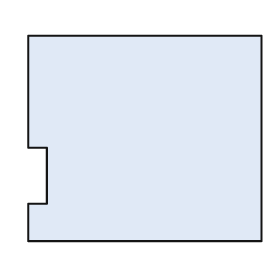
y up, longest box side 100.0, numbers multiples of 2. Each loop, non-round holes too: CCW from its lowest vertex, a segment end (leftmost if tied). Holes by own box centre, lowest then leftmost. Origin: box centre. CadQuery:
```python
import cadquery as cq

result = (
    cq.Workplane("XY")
    .moveTo(-50.0, -44.0)
    .lineTo(50.0, -44.0)
    .lineTo(50.0, 44.0)
    .lineTo(-50.0, 44.0)
    .lineTo(-50.0, -4.0)
    .lineTo(-42.0, -4.0)
    .lineTo(-42.0, -28.0)
    .lineTo(-50.0, -28.0)
    .close()
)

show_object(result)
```